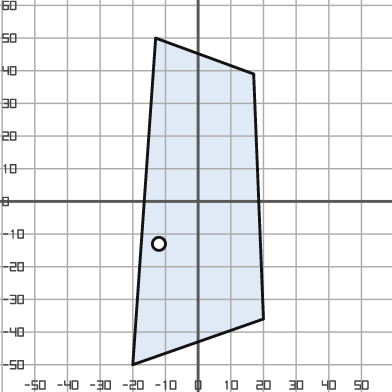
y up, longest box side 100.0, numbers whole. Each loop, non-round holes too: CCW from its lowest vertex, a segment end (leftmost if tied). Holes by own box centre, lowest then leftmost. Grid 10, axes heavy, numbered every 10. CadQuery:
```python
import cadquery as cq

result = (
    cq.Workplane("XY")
    .moveTo(-20.0, -50.0)
    .lineTo(20.0, -36.0)
    .lineTo(17.0, 39.0)
    .lineTo(-13.0, 50.0)
    .close()
    .moveTo(-12.0, -13.0)
    .circle(2.0)
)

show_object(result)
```